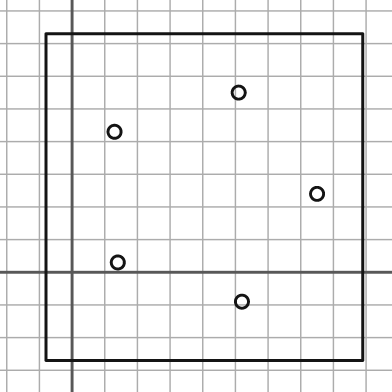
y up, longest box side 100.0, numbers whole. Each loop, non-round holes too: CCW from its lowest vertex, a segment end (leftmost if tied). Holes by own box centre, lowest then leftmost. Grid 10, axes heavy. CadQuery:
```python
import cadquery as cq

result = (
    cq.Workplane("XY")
    .moveTo(-8.0, -27.0)
    .lineTo(89.0, -27.0)
    .lineTo(89.0, 73.0)
    .lineTo(-8.0, 73.0)
    .close()
    .moveTo(52.0, -9.0)
    .circle(2.0)
    .moveTo(14.0, 3.0)
    .circle(2.0)
    .moveTo(75.0, 24.0)
    .circle(2.0)
    .moveTo(13.0, 43.0)
    .circle(2.0)
    .moveTo(51.0, 55.0)
    .circle(2.0)
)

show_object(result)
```